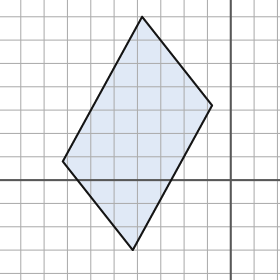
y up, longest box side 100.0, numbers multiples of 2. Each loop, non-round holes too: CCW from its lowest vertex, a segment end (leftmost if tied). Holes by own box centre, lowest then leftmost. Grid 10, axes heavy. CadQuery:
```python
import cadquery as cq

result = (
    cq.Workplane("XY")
    .moveTo(-42.0, -30.0)
    .lineTo(-8.0, 32.0)
    .lineTo(-38.0, 70.0)
    .lineTo(-72.0, 8.0)
    .close()
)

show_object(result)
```